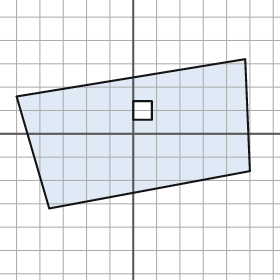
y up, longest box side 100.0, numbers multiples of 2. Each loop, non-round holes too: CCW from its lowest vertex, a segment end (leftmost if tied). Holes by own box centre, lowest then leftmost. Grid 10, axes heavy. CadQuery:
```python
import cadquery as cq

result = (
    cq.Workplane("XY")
    .moveTo(-36.0, -32.0)
    .lineTo(50.0, -16.0)
    .lineTo(48.0, 32.0)
    .lineTo(-50.0, 16.0)
    .close()
    .moveTo(0.0, 6.0)
    .lineTo(8.0, 6.0)
    .lineTo(8.0, 14.0)
    .lineTo(0.0, 14.0)
    .close()
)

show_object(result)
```